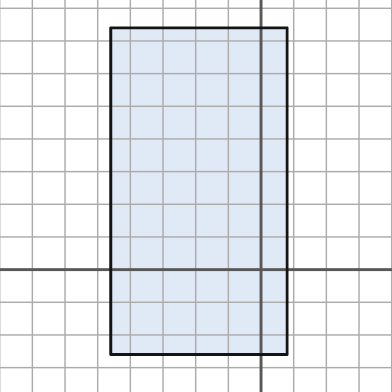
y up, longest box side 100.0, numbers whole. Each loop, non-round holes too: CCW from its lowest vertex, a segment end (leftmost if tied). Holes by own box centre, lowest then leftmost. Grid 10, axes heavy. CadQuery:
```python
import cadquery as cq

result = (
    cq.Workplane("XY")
    .moveTo(-46.0, -26.0)
    .lineTo(8.0, -26.0)
    .lineTo(8.0, 74.0)
    .lineTo(-46.0, 74.0)
    .close()
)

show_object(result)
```